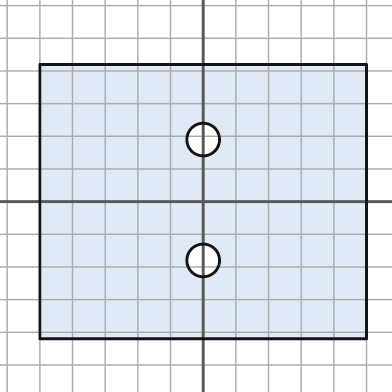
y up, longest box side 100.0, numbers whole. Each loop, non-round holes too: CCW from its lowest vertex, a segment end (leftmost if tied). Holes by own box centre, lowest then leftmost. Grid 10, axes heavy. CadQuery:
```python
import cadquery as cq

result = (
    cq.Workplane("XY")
    .moveTo(-50.0, -42.0)
    .lineTo(50.0, -42.0)
    .lineTo(50.0, 42.0)
    .lineTo(-50.0, 42.0)
    .close()
    .moveTo(0.0, -18.0)
    .circle(5.0)
    .moveTo(0.0, 19.0)
    .circle(5.0)
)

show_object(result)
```